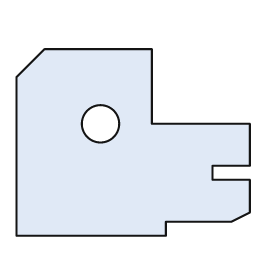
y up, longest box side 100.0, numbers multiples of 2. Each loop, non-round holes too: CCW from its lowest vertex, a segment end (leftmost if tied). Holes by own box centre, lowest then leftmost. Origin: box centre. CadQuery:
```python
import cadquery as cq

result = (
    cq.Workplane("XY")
    .moveTo(-50.0, -40.0)
    .lineTo(14.0, -40.0)
    .lineTo(14.0, -34.0)
    .lineTo(42.0, -34.0)
    .lineTo(50.0, -30.0)
    .lineTo(50.0, -16.0)
    .lineTo(34.0, -16.0)
    .lineTo(34.0, -10.0)
    .lineTo(50.0, -10.0)
    .lineTo(50.0, 8.0)
    .lineTo(8.0, 8.0)
    .lineTo(8.0, 40.0)
    .lineTo(-38.0, 40.0)
    .lineTo(-50.0, 28.0)
    .close()
    .moveTo(-14.0, 8.0)
    .circle(8.0)
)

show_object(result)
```